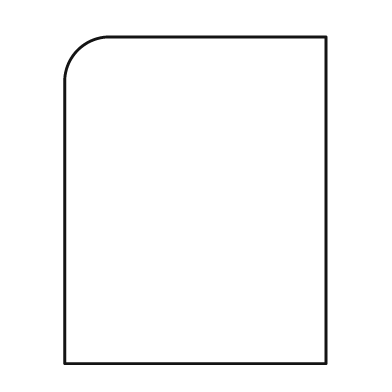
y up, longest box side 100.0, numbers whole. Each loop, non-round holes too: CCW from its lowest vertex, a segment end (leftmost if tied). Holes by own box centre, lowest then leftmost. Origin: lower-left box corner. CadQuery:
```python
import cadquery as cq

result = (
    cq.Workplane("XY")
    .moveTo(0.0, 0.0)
    .lineTo(80.0, 0.0)
    .lineTo(80.0, 100.0)
    .lineTo(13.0, 100.0)
    .threePointArc((4.0, 96.0), (0.0, 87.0))
    .close()
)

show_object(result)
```